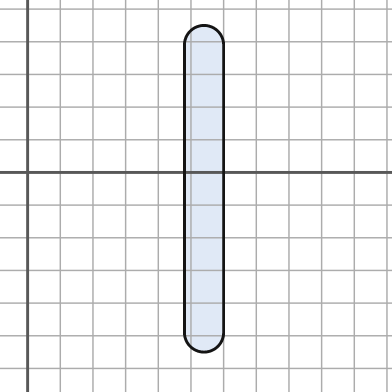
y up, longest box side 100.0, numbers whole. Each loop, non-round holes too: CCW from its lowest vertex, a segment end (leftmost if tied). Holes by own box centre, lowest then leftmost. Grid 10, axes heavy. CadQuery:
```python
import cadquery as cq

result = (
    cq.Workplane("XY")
    .moveTo(48.0, -49.0)
    .threePointArc((54.0, -55.0), (60.0, -49.0))
    .lineTo(60.0, 39.0)
    .threePointArc((54.0, 45.0), (48.0, 39.0))
    .close()
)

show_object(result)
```